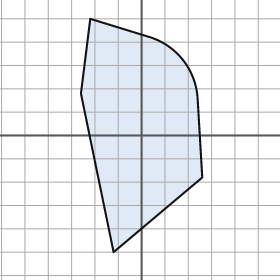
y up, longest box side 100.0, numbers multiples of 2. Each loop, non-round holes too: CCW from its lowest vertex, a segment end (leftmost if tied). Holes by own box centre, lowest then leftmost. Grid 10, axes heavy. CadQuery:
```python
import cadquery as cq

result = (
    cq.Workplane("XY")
    .moveTo(-12.0, -50.0)
    .lineTo(26.0, -18.0)
    .lineTo(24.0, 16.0)
    .threePointArc((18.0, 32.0), (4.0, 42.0))
    .lineTo(-22.0, 50.0)
    .lineTo(-26.0, 18.0)
    .close()
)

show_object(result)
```